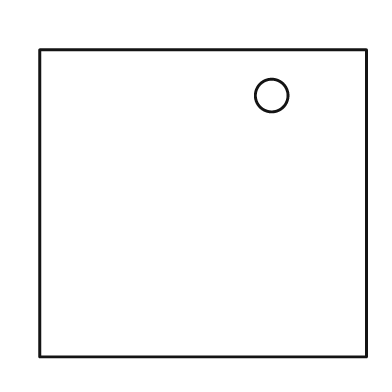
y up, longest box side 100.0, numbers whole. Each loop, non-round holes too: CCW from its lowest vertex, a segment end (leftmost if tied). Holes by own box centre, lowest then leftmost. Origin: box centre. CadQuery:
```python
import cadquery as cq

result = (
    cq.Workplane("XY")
    .moveTo(-50.0, -47.0)
    .lineTo(50.0, -47.0)
    .lineTo(50.0, 47.0)
    .lineTo(-50.0, 47.0)
    .close()
    .moveTo(21.0, 33.0)
    .circle(5.0)
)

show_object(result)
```